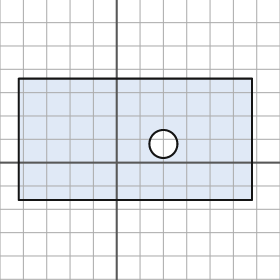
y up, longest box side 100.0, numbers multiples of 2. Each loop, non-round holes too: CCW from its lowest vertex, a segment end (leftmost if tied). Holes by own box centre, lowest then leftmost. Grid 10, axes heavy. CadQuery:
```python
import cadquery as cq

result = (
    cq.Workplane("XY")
    .moveTo(-42.0, -16.0)
    .lineTo(58.0, -16.0)
    .lineTo(58.0, 36.0)
    .lineTo(-42.0, 36.0)
    .close()
    .moveTo(20.0, 8.0)
    .circle(6.0)
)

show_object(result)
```